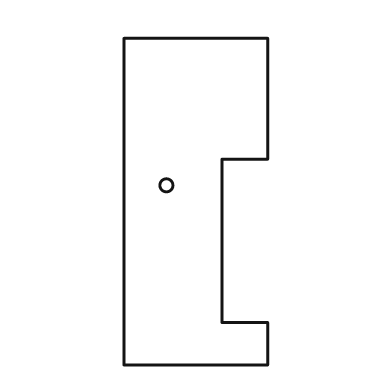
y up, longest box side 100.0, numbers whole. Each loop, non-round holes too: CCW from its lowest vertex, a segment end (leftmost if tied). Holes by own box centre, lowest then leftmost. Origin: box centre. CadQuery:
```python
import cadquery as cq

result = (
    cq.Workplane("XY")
    .moveTo(-22.0, -50.0)
    .lineTo(22.0, -50.0)
    .lineTo(22.0, -37.0)
    .lineTo(8.0, -37.0)
    .lineTo(8.0, 13.0)
    .lineTo(22.0, 13.0)
    .lineTo(22.0, 50.0)
    .lineTo(-22.0, 50.0)
    .close()
    .moveTo(-9.0, 5.0)
    .circle(2.0)
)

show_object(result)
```